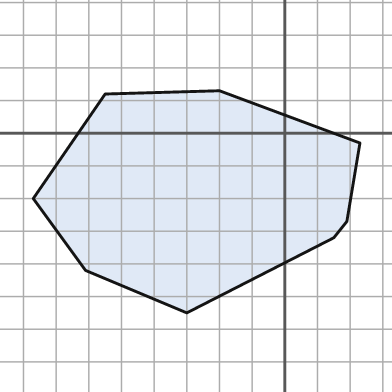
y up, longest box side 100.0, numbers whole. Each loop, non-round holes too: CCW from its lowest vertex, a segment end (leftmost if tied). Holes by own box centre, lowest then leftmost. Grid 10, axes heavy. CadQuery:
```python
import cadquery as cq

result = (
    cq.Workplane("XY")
    .moveTo(-30.0, -55.0)
    .lineTo(15.0, -32.0)
    .lineTo(19.0, -27.0)
    .lineTo(23.0, -3.0)
    .lineTo(-20.0, 13.0)
    .lineTo(-55.0, 12.0)
    .lineTo(-77.0, -20.0)
    .lineTo(-61.0, -42.0)
    .close()
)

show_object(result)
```